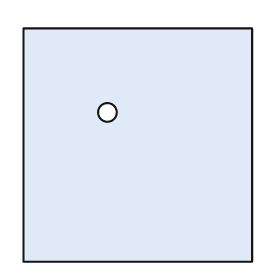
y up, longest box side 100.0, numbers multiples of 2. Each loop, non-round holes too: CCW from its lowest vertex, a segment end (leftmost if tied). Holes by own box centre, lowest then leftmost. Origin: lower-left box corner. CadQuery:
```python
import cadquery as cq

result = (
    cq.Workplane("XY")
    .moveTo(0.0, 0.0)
    .lineTo(98.0, 0.0)
    .lineTo(98.0, 100.0)
    .lineTo(0.0, 100.0)
    .close()
    .moveTo(36.0, 64.0)
    .circle(4.0)
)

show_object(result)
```